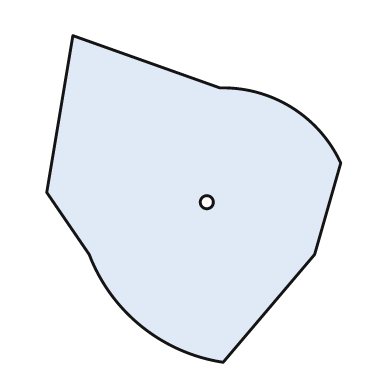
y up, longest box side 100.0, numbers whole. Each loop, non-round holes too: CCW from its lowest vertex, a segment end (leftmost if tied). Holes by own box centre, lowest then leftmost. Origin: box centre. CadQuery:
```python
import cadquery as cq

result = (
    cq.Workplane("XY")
    .moveTo(9.0, -50.0)
    .lineTo(37.0, -17.0)
    .lineTo(45.0, 11.0)
    .threePointArc((30.0, 28.0), (8.0, 34.0))
    .lineTo(-37.0, 50.0)
    .lineTo(-45.0, 2.0)
    .lineTo(-32.0, -17.0)
    .threePointArc((-16.0, -39.0), (9.0, -50.0))
    .close()
    .moveTo(4.0, -1.0)
    .circle(2.0)
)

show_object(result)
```